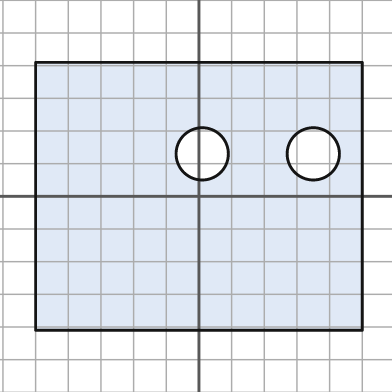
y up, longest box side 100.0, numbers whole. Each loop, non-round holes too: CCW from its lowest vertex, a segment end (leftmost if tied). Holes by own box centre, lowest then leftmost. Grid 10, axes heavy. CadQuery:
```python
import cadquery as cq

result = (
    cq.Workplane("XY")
    .moveTo(-50.0, -41.0)
    .lineTo(50.0, -41.0)
    .lineTo(50.0, 41.0)
    .lineTo(-50.0, 41.0)
    .close()
    .moveTo(1.0, 13.0)
    .circle(8.0)
    .moveTo(35.0, 13.0)
    .circle(8.0)
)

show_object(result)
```